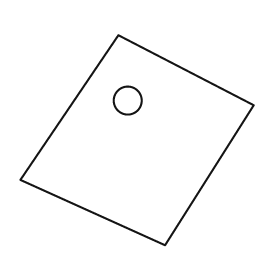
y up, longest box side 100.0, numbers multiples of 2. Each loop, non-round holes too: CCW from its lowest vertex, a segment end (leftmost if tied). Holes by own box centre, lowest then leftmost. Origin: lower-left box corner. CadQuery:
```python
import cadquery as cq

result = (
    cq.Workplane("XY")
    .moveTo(62.0, 0.0)
    .lineTo(100.0, 60.0)
    .lineTo(42.0, 90.0)
    .lineTo(0.0, 28.0)
    .close()
    .moveTo(46.0, 62.0)
    .circle(6.0)
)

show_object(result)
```